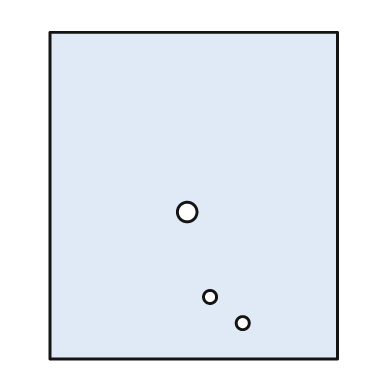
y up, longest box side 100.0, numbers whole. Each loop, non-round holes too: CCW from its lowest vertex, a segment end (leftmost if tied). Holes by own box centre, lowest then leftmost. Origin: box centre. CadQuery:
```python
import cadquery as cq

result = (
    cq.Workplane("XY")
    .moveTo(-44.0, -50.0)
    .lineTo(44.0, -50.0)
    .lineTo(44.0, 50.0)
    .lineTo(-44.0, 50.0)
    .close()
    .moveTo(15.0, -39.0)
    .circle(2.0)
    .moveTo(5.0, -31.0)
    .circle(2.0)
    .moveTo(-2.0, -5.0)
    .circle(3.0)
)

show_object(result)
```